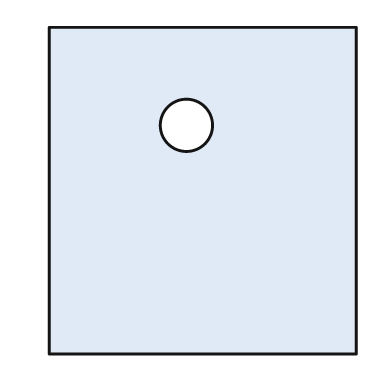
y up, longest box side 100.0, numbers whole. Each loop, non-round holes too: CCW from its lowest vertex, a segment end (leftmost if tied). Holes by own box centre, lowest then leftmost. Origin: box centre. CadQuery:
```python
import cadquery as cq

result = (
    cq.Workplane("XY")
    .moveTo(-47.0, -50.0)
    .lineTo(47.0, -50.0)
    .lineTo(47.0, 50.0)
    .lineTo(-47.0, 50.0)
    .close()
    .moveTo(-5.0, 20.0)
    .circle(8.0)
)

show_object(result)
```